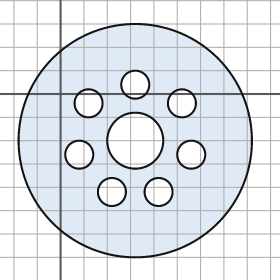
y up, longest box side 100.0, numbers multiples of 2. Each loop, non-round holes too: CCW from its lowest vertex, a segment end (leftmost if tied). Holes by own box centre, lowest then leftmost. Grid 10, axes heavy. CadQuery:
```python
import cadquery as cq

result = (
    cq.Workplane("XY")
    .moveTo(32.0, -20.0)
    .circle(50.0)
    .moveTo(22.0, -42.0)
    .circle(6.0)
    .moveTo(42.0, -42.0)
    .circle(6.0)
    .moveTo(8.0, -26.0)
    .circle(6.0)
    .moveTo(56.0, -26.0)
    .circle(6.0)
    .moveTo(32.0, -20.0)
    .circle(12.0)
    .moveTo(12.0, -4.0)
    .circle(6.0)
    .moveTo(52.0, -4.0)
    .circle(6.0)
    .moveTo(32.0, 4.0)
    .circle(6.0)
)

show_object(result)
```